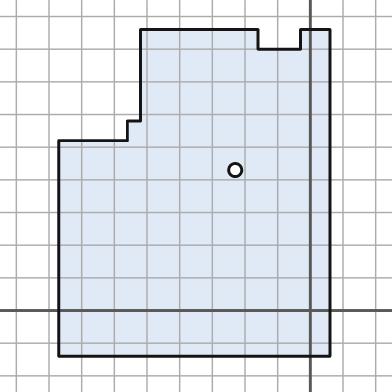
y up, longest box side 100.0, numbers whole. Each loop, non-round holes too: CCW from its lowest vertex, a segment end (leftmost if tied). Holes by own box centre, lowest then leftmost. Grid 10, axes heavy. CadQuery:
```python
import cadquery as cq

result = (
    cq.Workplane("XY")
    .moveTo(-77.0, -14.0)
    .lineTo(6.0, -14.0)
    .lineTo(6.0, 86.0)
    .lineTo(-3.0, 86.0)
    .lineTo(-3.0, 80.0)
    .lineTo(-16.0, 80.0)
    .lineTo(-16.0, 86.0)
    .lineTo(-52.0, 86.0)
    .lineTo(-52.0, 58.0)
    .lineTo(-56.0, 58.0)
    .lineTo(-56.0, 52.0)
    .lineTo(-77.0, 52.0)
    .close()
    .moveTo(-23.0, 43.0)
    .circle(2.0)
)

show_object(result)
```